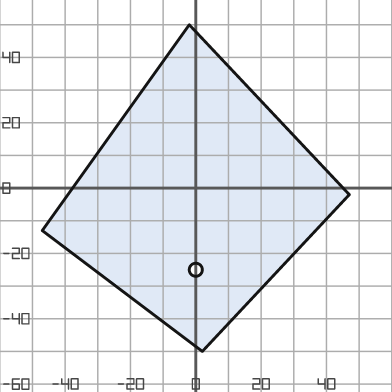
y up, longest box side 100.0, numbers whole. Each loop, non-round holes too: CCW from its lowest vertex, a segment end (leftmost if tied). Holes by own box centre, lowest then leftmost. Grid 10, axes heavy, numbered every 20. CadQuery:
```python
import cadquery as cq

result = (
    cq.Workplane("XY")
    .moveTo(2.0, -50.0)
    .lineTo(47.0, -2.0)
    .lineTo(-2.0, 50.0)
    .lineTo(-47.0, -13.0)
    .close()
    .moveTo(0.0, -25.0)
    .circle(2.0)
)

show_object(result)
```